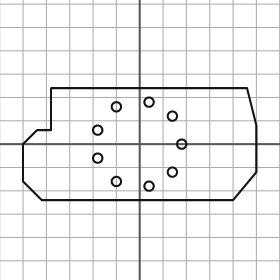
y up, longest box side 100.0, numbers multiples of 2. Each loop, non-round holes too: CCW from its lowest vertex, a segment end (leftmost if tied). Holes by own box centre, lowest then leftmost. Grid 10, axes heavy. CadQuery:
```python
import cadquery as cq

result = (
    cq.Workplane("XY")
    .moveTo(-42.0, -24.0)
    .lineTo(40.0, -24.0)
    .lineTo(50.0, -12.0)
    .lineTo(50.0, 8.0)
    .lineTo(46.0, 24.0)
    .lineTo(-38.0, 24.0)
    .lineTo(-38.0, 6.0)
    .lineTo(-44.0, 6.0)
    .lineTo(-50.0, 0.0)
    .lineTo(-50.0, -16.0)
    .close()
    .moveTo(4.0, -18.0)
    .circle(2.0)
    .moveTo(-10.0, -16.0)
    .circle(2.0)
    .moveTo(14.0, -12.0)
    .circle(2.0)
    .moveTo(-18.0, -6.0)
    .circle(2.0)
    .moveTo(18.0, 0.0)
    .circle(2.0)
    .moveTo(-18.0, 6.0)
    .circle(2.0)
    .moveTo(14.0, 12.0)
    .circle(2.0)
    .moveTo(-10.0, 16.0)
    .circle(2.0)
    .moveTo(4.0, 18.0)
    .circle(2.0)
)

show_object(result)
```